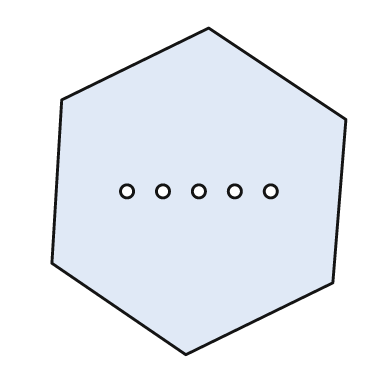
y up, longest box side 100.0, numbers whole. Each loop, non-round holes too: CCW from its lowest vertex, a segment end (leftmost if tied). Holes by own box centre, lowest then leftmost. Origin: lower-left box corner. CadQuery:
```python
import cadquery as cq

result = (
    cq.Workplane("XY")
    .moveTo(41.0, 0.0)
    .lineTo(86.0, 22.0)
    .lineTo(90.0, 72.0)
    .lineTo(48.0, 100.0)
    .lineTo(3.0, 78.0)
    .lineTo(0.0, 28.0)
    .close()
    .moveTo(23.0, 50.0)
    .circle(2.0)
    .moveTo(34.0, 50.0)
    .circle(2.0)
    .moveTo(45.0, 50.0)
    .circle(2.0)
    .moveTo(56.0, 50.0)
    .circle(2.0)
    .moveTo(67.0, 50.0)
    .circle(2.0)
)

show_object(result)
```